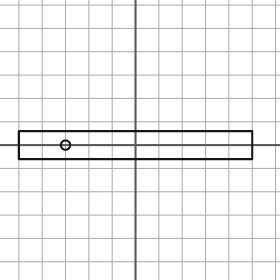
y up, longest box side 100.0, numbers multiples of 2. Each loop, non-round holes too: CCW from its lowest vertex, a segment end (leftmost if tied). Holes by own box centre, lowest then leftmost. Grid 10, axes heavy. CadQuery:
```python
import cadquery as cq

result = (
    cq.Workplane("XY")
    .moveTo(-50.0, -6.0)
    .lineTo(50.0, -6.0)
    .lineTo(50.0, 6.0)
    .lineTo(-50.0, 6.0)
    .close()
    .moveTo(-30.0, 0.0)
    .circle(2.0)
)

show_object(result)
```